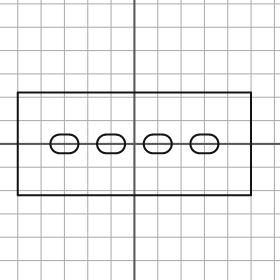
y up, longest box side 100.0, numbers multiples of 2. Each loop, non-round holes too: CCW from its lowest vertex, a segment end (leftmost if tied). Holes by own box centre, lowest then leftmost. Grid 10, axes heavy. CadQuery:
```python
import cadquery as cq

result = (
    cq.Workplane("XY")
    .moveTo(-50.0, -22.0)
    .lineTo(50.0, -22.0)
    .lineTo(50.0, 22.0)
    .lineTo(-50.0, 22.0)
    .close()
    .moveTo(-32.0, -4.0)
    .lineTo(-28.0, -4.0)
    .threePointArc((-24.0, 0.0), (-28.0, 4.0))
    .lineTo(-32.0, 4.0)
    .threePointArc((-36.0, 0.0), (-32.0, -4.0))
    .close()
    .moveTo(-12.0, -4.0)
    .lineTo(-8.0, -4.0)
    .threePointArc((-4.0, 0.0), (-8.0, 4.0))
    .lineTo(-12.0, 4.0)
    .threePointArc((-16.0, 0.0), (-12.0, -4.0))
    .close()
    .moveTo(8.0, -4.0)
    .lineTo(12.0, -4.0)
    .threePointArc((16.0, 0.0), (12.0, 4.0))
    .lineTo(8.0, 4.0)
    .threePointArc((4.0, 0.0), (8.0, -4.0))
    .close()
    .moveTo(28.0, -4.0)
    .lineTo(32.0, -4.0)
    .threePointArc((36.0, 0.0), (32.0, 4.0))
    .lineTo(28.0, 4.0)
    .threePointArc((24.0, 0.0), (28.0, -4.0))
    .close()
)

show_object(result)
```